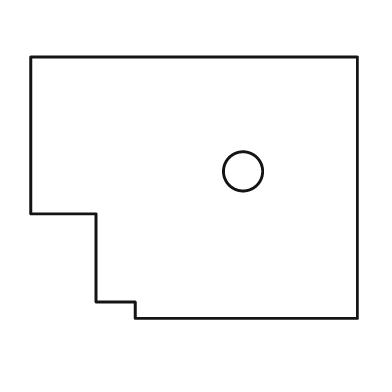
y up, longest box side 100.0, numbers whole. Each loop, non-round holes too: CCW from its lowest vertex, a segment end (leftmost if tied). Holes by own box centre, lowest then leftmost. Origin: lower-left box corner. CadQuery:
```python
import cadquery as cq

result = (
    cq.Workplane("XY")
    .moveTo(32.0, 0.0)
    .lineTo(100.0, 0.0)
    .lineTo(100.0, 80.0)
    .lineTo(0.0, 80.0)
    .lineTo(0.0, 32.0)
    .lineTo(20.0, 32.0)
    .lineTo(20.0, 5.0)
    .lineTo(32.0, 5.0)
    .close()
    .moveTo(65.0, 45.0)
    .circle(6.0)
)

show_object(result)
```